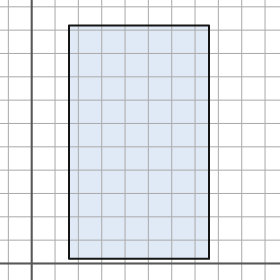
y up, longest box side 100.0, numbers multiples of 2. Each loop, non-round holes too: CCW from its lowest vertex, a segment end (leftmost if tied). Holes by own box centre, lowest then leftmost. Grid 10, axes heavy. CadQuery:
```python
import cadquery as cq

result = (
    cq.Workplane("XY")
    .moveTo(16.0, 2.0)
    .lineTo(76.0, 2.0)
    .lineTo(76.0, 102.0)
    .lineTo(16.0, 102.0)
    .close()
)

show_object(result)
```